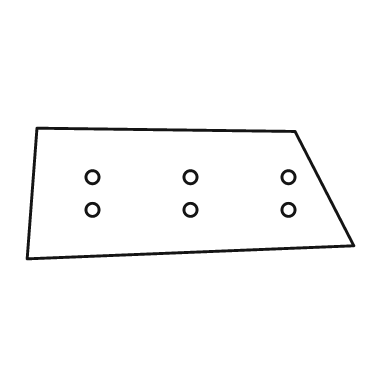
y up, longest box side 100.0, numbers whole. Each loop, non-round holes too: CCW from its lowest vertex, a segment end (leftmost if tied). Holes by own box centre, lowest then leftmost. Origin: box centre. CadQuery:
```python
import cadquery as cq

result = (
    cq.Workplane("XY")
    .moveTo(-50.0, -20.0)
    .lineTo(50.0, -16.0)
    .lineTo(32.0, 19.0)
    .lineTo(-47.0, 20.0)
    .close()
    .moveTo(-30.0, -5.0)
    .circle(2.0)
    .moveTo(0.0, -5.0)
    .circle(2.0)
    .moveTo(30.0, -5.0)
    .circle(2.0)
    .moveTo(-30.0, 5.0)
    .circle(2.0)
    .moveTo(0.0, 5.0)
    .circle(2.0)
    .moveTo(30.0, 5.0)
    .circle(2.0)
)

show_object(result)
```